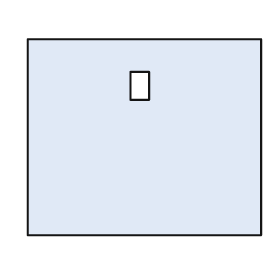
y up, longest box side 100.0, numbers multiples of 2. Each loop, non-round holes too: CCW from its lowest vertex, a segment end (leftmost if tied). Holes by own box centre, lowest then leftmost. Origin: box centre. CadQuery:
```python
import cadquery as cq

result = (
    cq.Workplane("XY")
    .moveTo(-50.0, -42.0)
    .lineTo(50.0, -42.0)
    .lineTo(50.0, 42.0)
    .lineTo(-50.0, 42.0)
    .close()
    .moveTo(-6.0, 16.0)
    .lineTo(2.0, 16.0)
    .lineTo(2.0, 28.0)
    .lineTo(-6.0, 28.0)
    .close()
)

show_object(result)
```